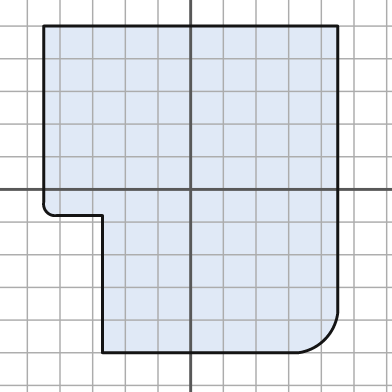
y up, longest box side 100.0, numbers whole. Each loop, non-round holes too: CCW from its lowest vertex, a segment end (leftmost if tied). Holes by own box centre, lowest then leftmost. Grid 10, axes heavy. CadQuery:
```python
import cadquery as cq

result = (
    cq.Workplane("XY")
    .moveTo(-27.0, -50.0)
    .lineTo(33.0, -50.0)
    .threePointArc((41.0, -46.0), (45.0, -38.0))
    .lineTo(45.0, 50.0)
    .lineTo(-45.0, 50.0)
    .lineTo(-45.0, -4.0)
    .threePointArc((-44.0, -7.0), (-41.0, -8.0))
    .lineTo(-27.0, -8.0)
    .close()
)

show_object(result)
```